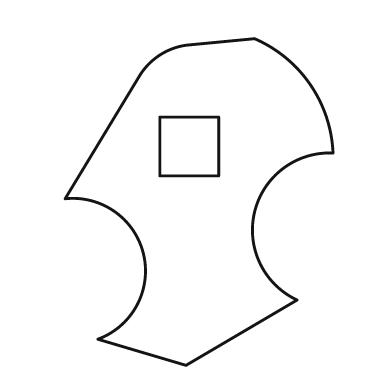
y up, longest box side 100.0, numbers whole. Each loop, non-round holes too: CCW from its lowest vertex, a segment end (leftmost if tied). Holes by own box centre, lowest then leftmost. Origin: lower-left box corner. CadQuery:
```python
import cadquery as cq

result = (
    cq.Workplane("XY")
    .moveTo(37.0, 0.0)
    .lineTo(71.0, 20.0)
    .threePointArc((58.0, 47.0), (82.0, 65.0))
    .threePointArc((75.0, 86.0), (58.0, 100.0))
    .lineTo(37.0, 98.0)
    .threePointArc((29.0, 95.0), (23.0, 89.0))
    .lineTo(0.0, 51.0)
    .threePointArc((24.0, 34.0), (10.0, 8.0))
    .close()
    .moveTo(29.0, 58.0)
    .lineTo(47.0, 58.0)
    .lineTo(47.0, 76.0)
    .lineTo(29.0, 76.0)
    .close()
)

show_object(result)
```